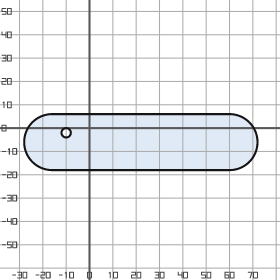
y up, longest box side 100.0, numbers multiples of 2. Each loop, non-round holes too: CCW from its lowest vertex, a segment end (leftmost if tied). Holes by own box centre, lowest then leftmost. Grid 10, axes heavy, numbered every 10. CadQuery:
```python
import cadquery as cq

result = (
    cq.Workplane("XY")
    .moveTo(-16.0, -18.0)
    .lineTo(60.0, -18.0)
    .threePointArc((72.0, -6.0), (60.0, 6.0))
    .lineTo(-16.0, 6.0)
    .threePointArc((-28.0, -6.0), (-16.0, -18.0))
    .close()
    .moveTo(-10.0, -2.0)
    .circle(2.0)
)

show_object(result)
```